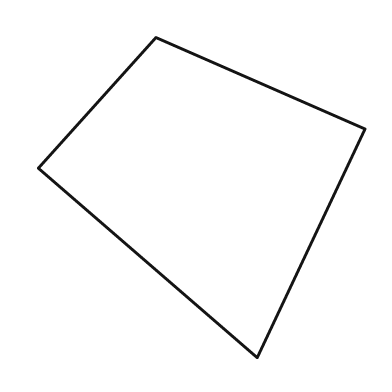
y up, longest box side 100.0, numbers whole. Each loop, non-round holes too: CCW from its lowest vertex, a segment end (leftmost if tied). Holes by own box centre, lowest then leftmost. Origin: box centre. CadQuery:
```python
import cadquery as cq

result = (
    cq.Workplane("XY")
    .moveTo(17.0, -49.0)
    .lineTo(50.0, 21.0)
    .lineTo(-14.0, 49.0)
    .lineTo(-50.0, 9.0)
    .close()
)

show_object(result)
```